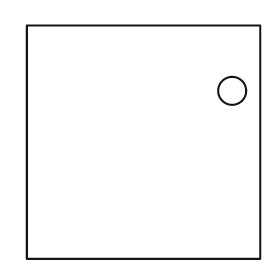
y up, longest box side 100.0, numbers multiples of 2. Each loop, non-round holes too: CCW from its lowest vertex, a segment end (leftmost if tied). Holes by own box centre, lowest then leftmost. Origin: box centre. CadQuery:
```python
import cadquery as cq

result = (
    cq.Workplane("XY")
    .moveTo(-50.0, -50.0)
    .lineTo(50.0, -50.0)
    .lineTo(50.0, 50.0)
    .lineTo(-50.0, 50.0)
    .close()
    .moveTo(38.0, 22.0)
    .circle(6.0)
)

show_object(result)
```